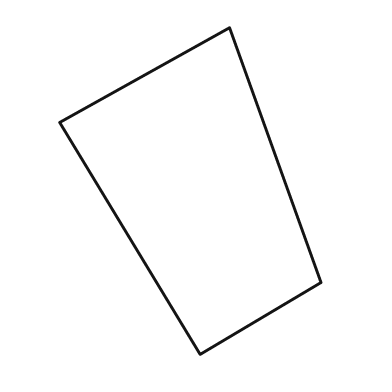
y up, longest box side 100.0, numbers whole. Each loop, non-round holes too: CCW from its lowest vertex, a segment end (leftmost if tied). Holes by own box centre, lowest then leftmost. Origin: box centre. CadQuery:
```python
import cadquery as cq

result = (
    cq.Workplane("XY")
    .moveTo(3.0, -50.0)
    .lineTo(40.0, -28.0)
    .lineTo(12.0, 50.0)
    .lineTo(-40.0, 21.0)
    .close()
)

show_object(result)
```